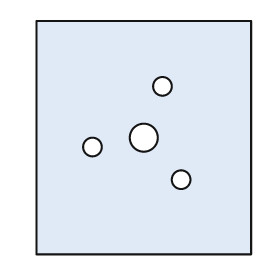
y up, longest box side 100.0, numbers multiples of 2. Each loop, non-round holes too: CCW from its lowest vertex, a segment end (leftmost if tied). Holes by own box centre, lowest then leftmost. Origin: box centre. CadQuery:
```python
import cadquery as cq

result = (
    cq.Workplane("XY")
    .moveTo(-46.0, -50.0)
    .lineTo(46.0, -50.0)
    .lineTo(46.0, 50.0)
    .lineTo(-46.0, 50.0)
    .close()
    .moveTo(16.0, -18.0)
    .circle(4.0)
    .moveTo(-22.0, -4.0)
    .circle(4.0)
    .moveTo(0.0, 0.0)
    .circle(6.0)
    .moveTo(8.0, 22.0)
    .circle(4.0)
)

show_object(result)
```